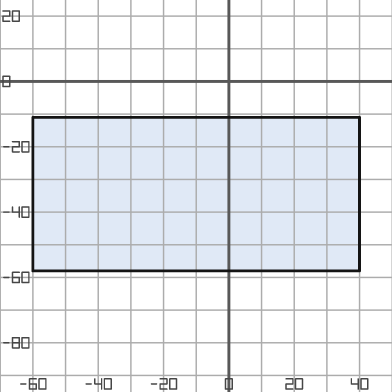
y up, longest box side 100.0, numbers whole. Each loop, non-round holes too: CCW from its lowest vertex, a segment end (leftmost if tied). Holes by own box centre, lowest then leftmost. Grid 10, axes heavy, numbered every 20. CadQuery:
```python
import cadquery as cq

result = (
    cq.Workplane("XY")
    .moveTo(-60.0, -58.0)
    .lineTo(40.0, -58.0)
    .lineTo(40.0, -11.0)
    .lineTo(-60.0, -11.0)
    .close()
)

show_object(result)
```